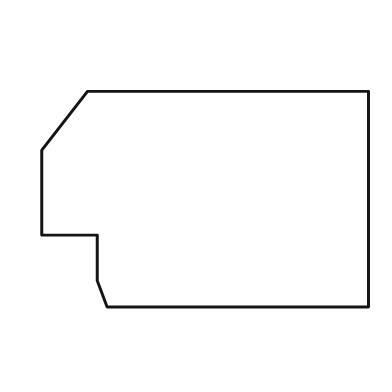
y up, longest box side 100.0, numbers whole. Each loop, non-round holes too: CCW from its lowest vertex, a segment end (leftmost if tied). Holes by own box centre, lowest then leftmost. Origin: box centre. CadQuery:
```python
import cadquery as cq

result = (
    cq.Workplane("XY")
    .moveTo(-30.0, -33.0)
    .lineTo(50.0, -33.0)
    .lineTo(50.0, 33.0)
    .lineTo(-36.0, 33.0)
    .lineTo(-50.0, 15.0)
    .lineTo(-50.0, -11.0)
    .lineTo(-33.0, -11.0)
    .lineTo(-33.0, -25.0)
    .close()
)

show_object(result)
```